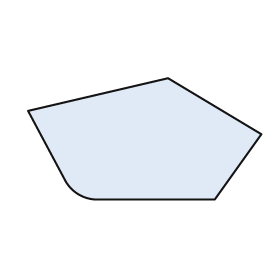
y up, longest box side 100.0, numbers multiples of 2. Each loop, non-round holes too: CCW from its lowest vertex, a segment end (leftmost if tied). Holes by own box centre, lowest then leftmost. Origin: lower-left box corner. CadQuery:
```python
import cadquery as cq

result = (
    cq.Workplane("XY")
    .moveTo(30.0, 0.0)
    .lineTo(80.0, 0.0)
    .lineTo(100.0, 28.0)
    .lineTo(60.0, 52.0)
    .lineTo(0.0, 38.0)
    .lineTo(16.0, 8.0)
    .threePointArc((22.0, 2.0), (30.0, 0.0))
    .close()
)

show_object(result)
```